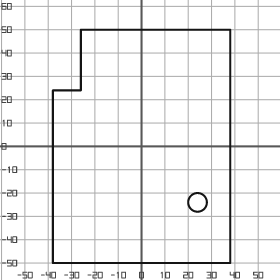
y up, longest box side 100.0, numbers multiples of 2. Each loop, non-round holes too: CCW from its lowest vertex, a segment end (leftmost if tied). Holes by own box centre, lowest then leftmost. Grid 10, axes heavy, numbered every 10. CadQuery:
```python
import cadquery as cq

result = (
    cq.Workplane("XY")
    .moveTo(-38.0, -50.0)
    .lineTo(38.0, -50.0)
    .lineTo(38.0, 50.0)
    .lineTo(-26.0, 50.0)
    .lineTo(-26.0, 24.0)
    .lineTo(-38.0, 24.0)
    .close()
    .moveTo(24.0, -24.0)
    .circle(4.0)
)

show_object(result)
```